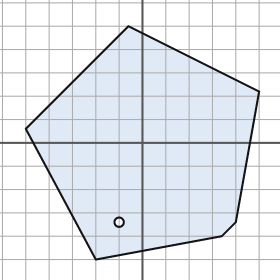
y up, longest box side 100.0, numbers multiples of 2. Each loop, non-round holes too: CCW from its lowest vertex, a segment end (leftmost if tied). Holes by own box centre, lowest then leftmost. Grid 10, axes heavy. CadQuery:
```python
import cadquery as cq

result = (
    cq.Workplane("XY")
    .moveTo(-20.0, -50.0)
    .lineTo(34.0, -40.0)
    .lineTo(40.0, -34.0)
    .lineTo(50.0, 22.0)
    .lineTo(-6.0, 50.0)
    .lineTo(-50.0, 6.0)
    .close()
    .moveTo(-10.0, -34.0)
    .circle(2.0)
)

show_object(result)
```